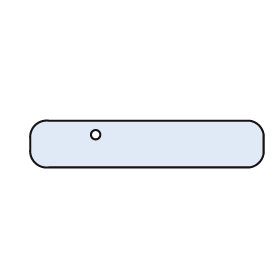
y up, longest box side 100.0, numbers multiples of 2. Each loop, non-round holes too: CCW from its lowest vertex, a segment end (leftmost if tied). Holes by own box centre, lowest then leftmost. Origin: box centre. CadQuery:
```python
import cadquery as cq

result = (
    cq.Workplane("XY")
    .moveTo(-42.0, -10.0)
    .lineTo(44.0, -10.0)
    .threePointArc((48.0, -8.0), (50.0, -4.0))
    .lineTo(50.0, 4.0)
    .threePointArc((48.0, 8.0), (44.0, 10.0))
    .lineTo(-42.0, 10.0)
    .threePointArc((-48.0, 8.0), (-50.0, 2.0))
    .lineTo(-50.0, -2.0)
    .threePointArc((-48.0, -8.0), (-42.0, -10.0))
    .close()
    .moveTo(-22.0, 4.0)
    .circle(2.0)
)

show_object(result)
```